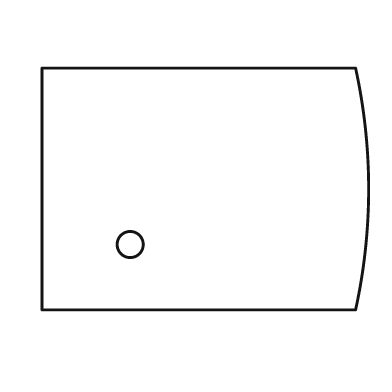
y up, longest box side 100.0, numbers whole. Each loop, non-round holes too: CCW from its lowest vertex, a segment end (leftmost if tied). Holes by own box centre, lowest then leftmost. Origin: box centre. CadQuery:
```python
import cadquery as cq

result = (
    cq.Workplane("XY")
    .moveTo(-50.0, -37.0)
    .lineTo(46.0, -37.0)
    .threePointArc((50.0, 0.0), (46.0, 37.0))
    .lineTo(-50.0, 37.0)
    .close()
    .moveTo(-23.0, -17.0)
    .circle(4.0)
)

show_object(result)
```